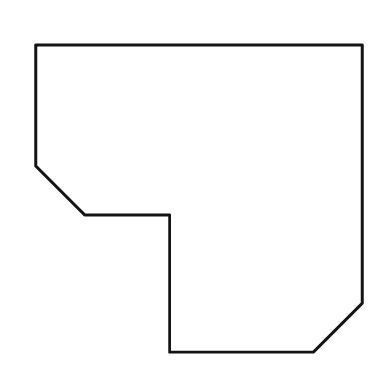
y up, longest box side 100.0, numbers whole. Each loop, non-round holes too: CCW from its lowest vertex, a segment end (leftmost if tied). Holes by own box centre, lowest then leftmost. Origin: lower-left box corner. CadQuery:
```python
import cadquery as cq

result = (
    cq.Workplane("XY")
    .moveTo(41.0, 0.0)
    .lineTo(85.0, 0.0)
    .lineTo(100.0, 15.0)
    .lineTo(100.0, 94.0)
    .lineTo(0.0, 94.0)
    .lineTo(0.0, 57.0)
    .lineTo(15.0, 42.0)
    .lineTo(41.0, 42.0)
    .close()
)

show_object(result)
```